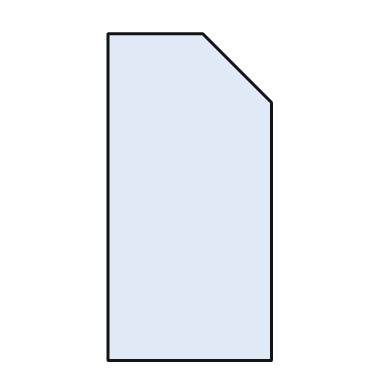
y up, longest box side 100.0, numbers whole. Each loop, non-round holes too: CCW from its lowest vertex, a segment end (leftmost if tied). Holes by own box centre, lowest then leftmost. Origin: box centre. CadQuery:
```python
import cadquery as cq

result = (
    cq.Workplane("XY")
    .moveTo(-25.0, -50.0)
    .lineTo(25.0, -50.0)
    .lineTo(25.0, 29.0)
    .lineTo(4.0, 50.0)
    .lineTo(-25.0, 50.0)
    .close()
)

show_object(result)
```